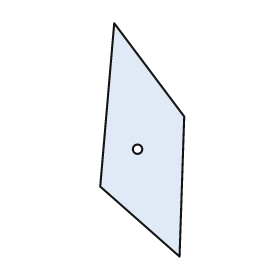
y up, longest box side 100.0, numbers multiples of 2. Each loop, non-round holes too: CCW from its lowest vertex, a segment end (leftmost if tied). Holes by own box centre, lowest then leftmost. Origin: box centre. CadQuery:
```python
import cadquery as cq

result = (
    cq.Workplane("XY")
    .moveTo(16.0, -50.0)
    .lineTo(18.0, 10.0)
    .lineTo(-12.0, 50.0)
    .lineTo(-18.0, -20.0)
    .close()
    .moveTo(-2.0, -4.0)
    .circle(2.0)
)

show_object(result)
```